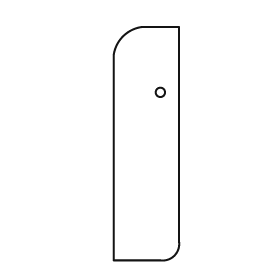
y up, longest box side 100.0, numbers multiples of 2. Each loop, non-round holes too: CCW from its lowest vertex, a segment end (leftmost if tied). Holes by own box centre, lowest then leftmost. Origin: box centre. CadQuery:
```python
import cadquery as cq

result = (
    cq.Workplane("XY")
    .moveTo(-14.0, -50.0)
    .lineTo(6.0, -50.0)
    .threePointArc((12.0, -48.0), (14.0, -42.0))
    .lineTo(14.0, 50.0)
    .lineTo(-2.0, 50.0)
    .threePointArc((-10.0, 46.0), (-14.0, 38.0))
    .close()
    .moveTo(6.0, 22.0)
    .circle(2.0)
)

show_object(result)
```